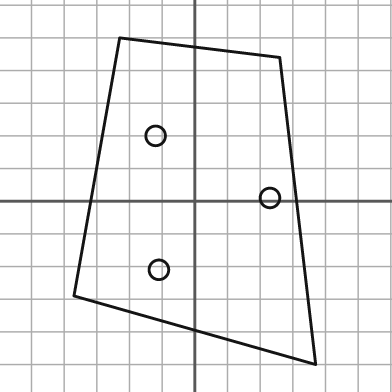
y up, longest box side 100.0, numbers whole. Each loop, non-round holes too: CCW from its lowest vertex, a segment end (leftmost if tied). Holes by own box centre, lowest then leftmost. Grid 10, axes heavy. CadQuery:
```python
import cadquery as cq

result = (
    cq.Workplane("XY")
    .moveTo(37.0, -50.0)
    .lineTo(26.0, 44.0)
    .lineTo(-23.0, 50.0)
    .lineTo(-37.0, -29.0)
    .close()
    .moveTo(-11.0, -21.0)
    .circle(3.0)
    .moveTo(23.0, 1.0)
    .circle(3.0)
    .moveTo(-12.0, 20.0)
    .circle(3.0)
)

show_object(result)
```